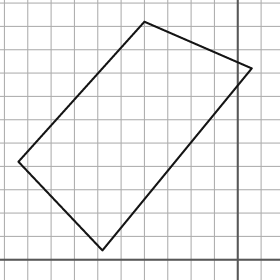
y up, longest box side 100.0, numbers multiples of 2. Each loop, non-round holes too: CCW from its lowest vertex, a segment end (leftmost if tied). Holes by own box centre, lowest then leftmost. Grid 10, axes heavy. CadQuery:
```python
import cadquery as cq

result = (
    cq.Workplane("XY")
    .moveTo(-58.0, 4.0)
    .lineTo(6.0, 82.0)
    .lineTo(-40.0, 102.0)
    .lineTo(-94.0, 42.0)
    .close()
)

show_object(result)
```